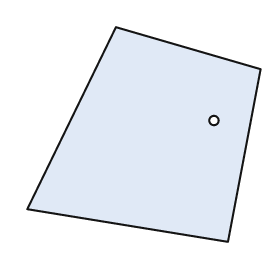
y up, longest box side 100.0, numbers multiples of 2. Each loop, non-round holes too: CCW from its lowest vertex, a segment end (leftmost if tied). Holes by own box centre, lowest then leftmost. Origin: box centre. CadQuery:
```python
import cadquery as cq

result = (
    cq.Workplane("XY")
    .moveTo(36.0, -46.0)
    .lineTo(50.0, 28.0)
    .lineTo(-12.0, 46.0)
    .lineTo(-50.0, -32.0)
    .close()
    .moveTo(30.0, 6.0)
    .circle(2.0)
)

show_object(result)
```